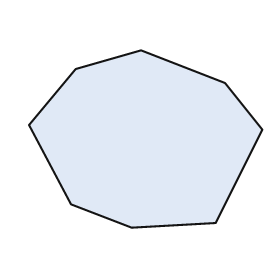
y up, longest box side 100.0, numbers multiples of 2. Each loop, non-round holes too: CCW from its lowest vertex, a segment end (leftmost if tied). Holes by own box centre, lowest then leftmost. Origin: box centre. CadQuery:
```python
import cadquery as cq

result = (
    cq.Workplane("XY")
    .moveTo(-6.0, -38.0)
    .lineTo(30.0, -36.0)
    .lineTo(50.0, 4.0)
    .lineTo(34.0, 24.0)
    .lineTo(-2.0, 38.0)
    .lineTo(-30.0, 30.0)
    .lineTo(-50.0, 6.0)
    .lineTo(-32.0, -28.0)
    .close()
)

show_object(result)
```